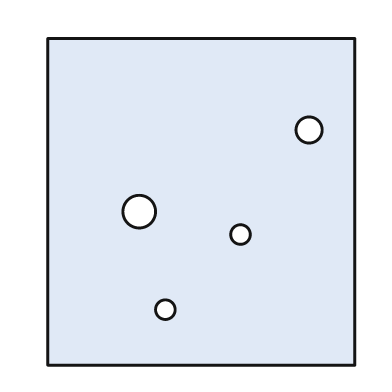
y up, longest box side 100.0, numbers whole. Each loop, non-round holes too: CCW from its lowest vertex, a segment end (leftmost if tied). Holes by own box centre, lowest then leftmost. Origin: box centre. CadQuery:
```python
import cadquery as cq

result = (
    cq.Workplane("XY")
    .moveTo(-47.0, -50.0)
    .lineTo(47.0, -50.0)
    .lineTo(47.0, 50.0)
    .lineTo(-47.0, 50.0)
    .close()
    .moveTo(-11.0, -33.0)
    .circle(3.0)
    .moveTo(12.0, -10.0)
    .circle(3.0)
    .moveTo(-19.0, -3.0)
    .circle(5.0)
    .moveTo(33.0, 22.0)
    .circle(4.0)
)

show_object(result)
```